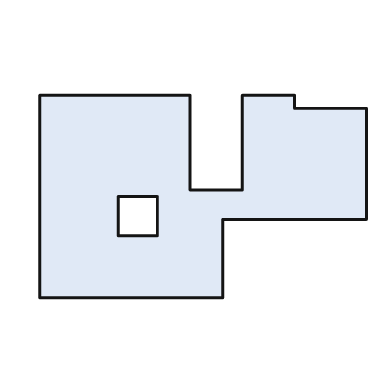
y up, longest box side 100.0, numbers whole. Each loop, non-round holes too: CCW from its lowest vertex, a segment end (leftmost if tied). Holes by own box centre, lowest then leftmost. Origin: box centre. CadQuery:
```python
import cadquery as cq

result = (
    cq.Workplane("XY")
    .moveTo(-50.0, -31.0)
    .lineTo(6.0, -31.0)
    .lineTo(6.0, -7.0)
    .lineTo(50.0, -7.0)
    .lineTo(50.0, 27.0)
    .lineTo(28.0, 27.0)
    .lineTo(28.0, 31.0)
    .lineTo(12.0, 31.0)
    .lineTo(12.0, 2.0)
    .lineTo(-4.0, 2.0)
    .lineTo(-4.0, 31.0)
    .lineTo(-50.0, 31.0)
    .close()
    .moveTo(-26.0, -12.0)
    .lineTo(-14.0, -12.0)
    .lineTo(-14.0, 0.0)
    .lineTo(-26.0, 0.0)
    .close()
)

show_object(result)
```